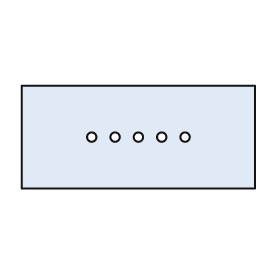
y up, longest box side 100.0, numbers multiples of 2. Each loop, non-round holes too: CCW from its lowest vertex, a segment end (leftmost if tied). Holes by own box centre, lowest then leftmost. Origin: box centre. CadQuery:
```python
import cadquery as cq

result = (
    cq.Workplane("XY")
    .moveTo(-50.0, -22.0)
    .lineTo(50.0, -22.0)
    .lineTo(50.0, 22.0)
    .lineTo(-50.0, 22.0)
    .close()
    .moveTo(-20.0, 0.0)
    .circle(2.0)
    .moveTo(-10.0, 0.0)
    .circle(2.0)
    .moveTo(0.0, 0.0)
    .circle(2.0)
    .moveTo(10.0, 0.0)
    .circle(2.0)
    .moveTo(20.0, 0.0)
    .circle(2.0)
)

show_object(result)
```